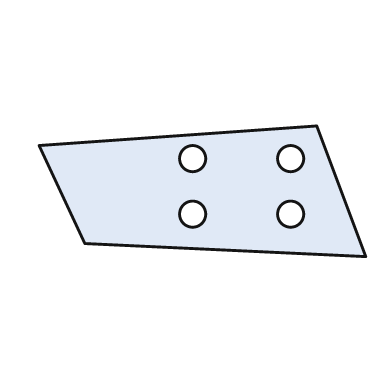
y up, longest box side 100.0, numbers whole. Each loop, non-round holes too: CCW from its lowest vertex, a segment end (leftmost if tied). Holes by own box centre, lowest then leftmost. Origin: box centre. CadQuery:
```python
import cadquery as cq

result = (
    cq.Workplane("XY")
    .moveTo(50.0, -20.0)
    .lineTo(35.0, 20.0)
    .lineTo(-50.0, 14.0)
    .lineTo(-36.0, -16.0)
    .close()
    .moveTo(-3.0, -7.0)
    .circle(4.0)
    .moveTo(27.0, -7.0)
    .circle(4.0)
    .moveTo(-3.0, 10.0)
    .circle(4.0)
    .moveTo(27.0, 10.0)
    .circle(4.0)
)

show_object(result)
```